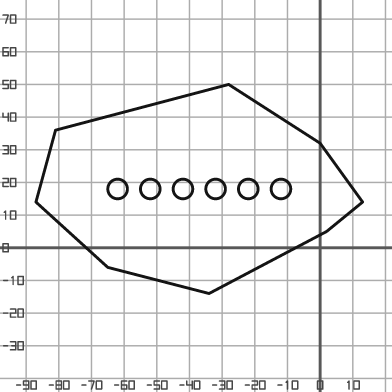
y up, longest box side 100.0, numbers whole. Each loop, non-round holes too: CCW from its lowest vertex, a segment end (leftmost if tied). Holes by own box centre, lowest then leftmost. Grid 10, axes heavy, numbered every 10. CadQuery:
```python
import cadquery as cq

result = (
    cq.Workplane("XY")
    .moveTo(-34.0, -14.0)
    .lineTo(2.0, 5.0)
    .lineTo(13.0, 14.0)
    .lineTo(0.0, 32.0)
    .lineTo(-28.0, 50.0)
    .lineTo(-81.0, 36.0)
    .lineTo(-87.0, 14.0)
    .lineTo(-65.0, -6.0)
    .close()
    .moveTo(-62.0, 18.0)
    .circle(3.0)
    .moveTo(-52.0, 18.0)
    .circle(3.0)
    .moveTo(-42.0, 18.0)
    .circle(3.0)
    .moveTo(-32.0, 18.0)
    .circle(3.0)
    .moveTo(-22.0, 18.0)
    .circle(3.0)
    .moveTo(-12.0, 18.0)
    .circle(3.0)
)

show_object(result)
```